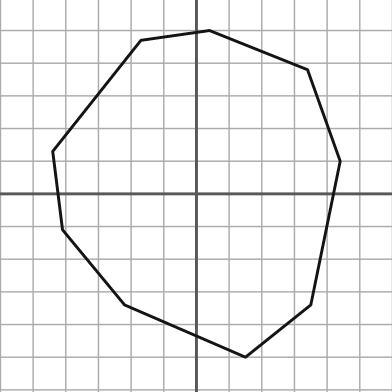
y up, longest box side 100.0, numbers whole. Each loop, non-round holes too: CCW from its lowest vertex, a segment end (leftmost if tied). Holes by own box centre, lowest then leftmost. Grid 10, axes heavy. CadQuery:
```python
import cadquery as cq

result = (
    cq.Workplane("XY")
    .moveTo(15.0, -50.0)
    .lineTo(35.0, -34.0)
    .lineTo(44.0, 10.0)
    .lineTo(34.0, 38.0)
    .lineTo(4.0, 50.0)
    .lineTo(-17.0, 47.0)
    .lineTo(-44.0, 13.0)
    .lineTo(-41.0, -11.0)
    .lineTo(-22.0, -34.0)
    .close()
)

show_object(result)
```